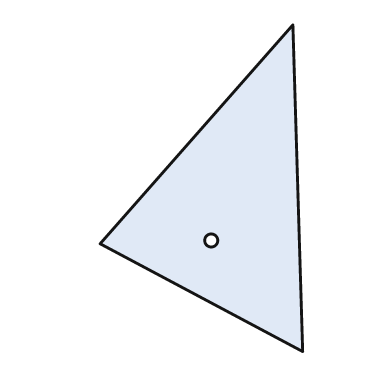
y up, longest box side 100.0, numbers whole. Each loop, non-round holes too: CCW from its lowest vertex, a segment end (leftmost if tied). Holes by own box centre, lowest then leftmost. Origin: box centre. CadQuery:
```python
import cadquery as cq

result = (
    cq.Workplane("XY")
    .moveTo(31.0, -50.0)
    .lineTo(28.0, 50.0)
    .lineTo(-31.0, -17.0)
    .close()
    .moveTo(3.0, -16.0)
    .circle(2.0)
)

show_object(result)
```